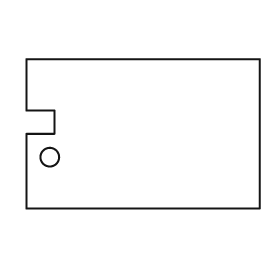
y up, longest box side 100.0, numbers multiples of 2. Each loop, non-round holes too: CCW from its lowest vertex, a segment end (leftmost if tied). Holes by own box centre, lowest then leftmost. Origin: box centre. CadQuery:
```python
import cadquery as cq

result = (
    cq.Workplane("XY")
    .moveTo(-50.0, -32.0)
    .lineTo(50.0, -32.0)
    .lineTo(50.0, 32.0)
    .lineTo(-50.0, 32.0)
    .lineTo(-50.0, 10.0)
    .lineTo(-38.0, 10.0)
    .lineTo(-38.0, 0.0)
    .lineTo(-50.0, 0.0)
    .close()
    .moveTo(-40.0, -10.0)
    .circle(4.0)
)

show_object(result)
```